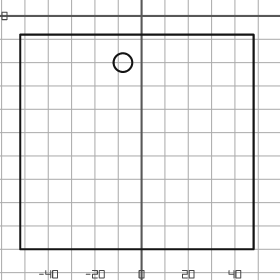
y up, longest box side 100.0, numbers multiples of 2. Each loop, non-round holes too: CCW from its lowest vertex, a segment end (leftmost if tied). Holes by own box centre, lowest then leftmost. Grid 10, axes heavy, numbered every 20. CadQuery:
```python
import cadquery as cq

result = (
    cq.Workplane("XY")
    .moveTo(-52.0, -100.0)
    .lineTo(48.0, -100.0)
    .lineTo(48.0, -8.0)
    .lineTo(-52.0, -8.0)
    .close()
    .moveTo(-8.0, -20.0)
    .circle(4.0)
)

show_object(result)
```